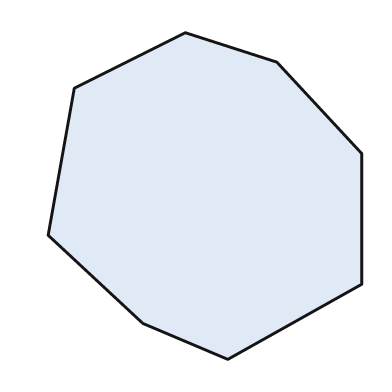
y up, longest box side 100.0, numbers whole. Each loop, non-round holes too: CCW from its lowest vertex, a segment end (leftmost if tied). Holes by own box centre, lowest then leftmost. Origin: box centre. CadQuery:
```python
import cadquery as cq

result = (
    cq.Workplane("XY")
    .moveTo(7.0, -50.0)
    .lineTo(48.0, -27.0)
    .lineTo(48.0, 13.0)
    .lineTo(22.0, 41.0)
    .lineTo(-6.0, 50.0)
    .lineTo(-40.0, 33.0)
    .lineTo(-48.0, -12.0)
    .lineTo(-19.0, -39.0)
    .close()
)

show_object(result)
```